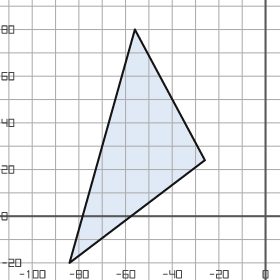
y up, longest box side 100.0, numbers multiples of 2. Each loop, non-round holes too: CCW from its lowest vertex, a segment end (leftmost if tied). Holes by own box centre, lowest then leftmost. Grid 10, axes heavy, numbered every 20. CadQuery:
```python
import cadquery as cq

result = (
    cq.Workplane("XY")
    .moveTo(-84.0, -20.0)
    .lineTo(-26.0, 24.0)
    .lineTo(-56.0, 80.0)
    .close()
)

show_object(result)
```